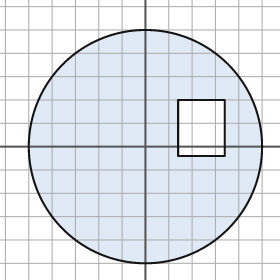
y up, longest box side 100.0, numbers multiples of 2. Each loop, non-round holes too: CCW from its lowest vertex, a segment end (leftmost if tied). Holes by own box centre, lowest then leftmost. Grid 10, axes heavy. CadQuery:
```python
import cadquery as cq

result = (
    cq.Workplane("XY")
    .moveTo(0.0, 0.0)
    .circle(50.0)
    .moveTo(14.0, -4.0)
    .lineTo(34.0, -4.0)
    .lineTo(34.0, 20.0)
    .lineTo(14.0, 20.0)
    .close()
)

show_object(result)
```